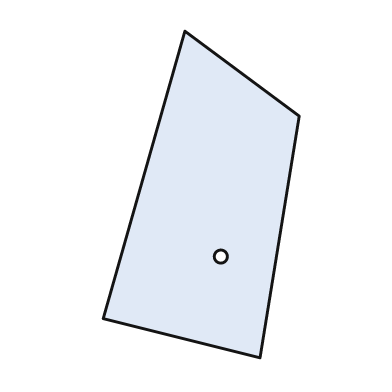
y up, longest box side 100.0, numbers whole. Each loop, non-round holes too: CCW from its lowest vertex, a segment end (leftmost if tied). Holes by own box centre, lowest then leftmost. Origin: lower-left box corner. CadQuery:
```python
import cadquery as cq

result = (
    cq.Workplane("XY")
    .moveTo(48.0, 0.0)
    .lineTo(60.0, 74.0)
    .lineTo(25.0, 100.0)
    .lineTo(0.0, 12.0)
    .close()
    .moveTo(36.0, 31.0)
    .circle(2.0)
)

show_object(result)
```